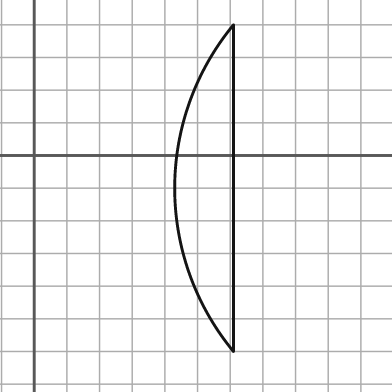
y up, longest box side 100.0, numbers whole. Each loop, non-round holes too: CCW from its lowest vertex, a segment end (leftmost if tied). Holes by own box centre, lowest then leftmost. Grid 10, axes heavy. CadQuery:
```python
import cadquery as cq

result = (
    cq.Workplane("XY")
    .moveTo(61.0, -60.0)
    .lineTo(61.0, 40.0)
    .threePointArc((43.0, -10.0), (61.0, -60.0))
    .close()
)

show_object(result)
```